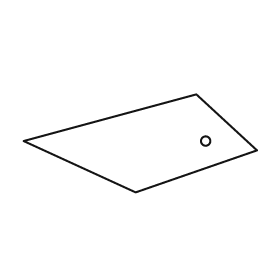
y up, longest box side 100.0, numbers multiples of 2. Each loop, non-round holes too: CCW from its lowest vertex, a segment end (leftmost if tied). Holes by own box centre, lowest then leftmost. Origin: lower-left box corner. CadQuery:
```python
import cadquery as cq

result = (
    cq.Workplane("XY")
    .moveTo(48.0, 0.0)
    .lineTo(100.0, 18.0)
    .lineTo(74.0, 42.0)
    .lineTo(0.0, 22.0)
    .close()
    .moveTo(78.0, 22.0)
    .circle(2.0)
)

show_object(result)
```